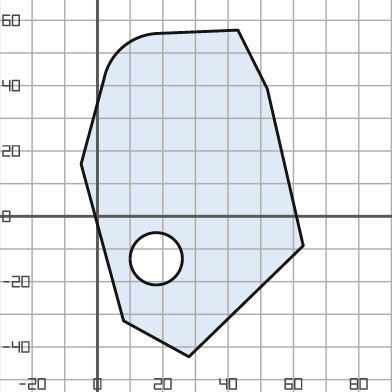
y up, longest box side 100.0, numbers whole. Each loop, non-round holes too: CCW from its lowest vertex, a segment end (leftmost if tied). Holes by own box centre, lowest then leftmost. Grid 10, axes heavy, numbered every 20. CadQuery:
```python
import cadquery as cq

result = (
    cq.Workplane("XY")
    .moveTo(28.0, -43.0)
    .lineTo(63.0, -9.0)
    .lineTo(52.0, 39.0)
    .lineTo(43.0, 57.0)
    .lineTo(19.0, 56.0)
    .threePointArc((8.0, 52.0), (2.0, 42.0))
    .lineTo(-5.0, 16.0)
    .lineTo(8.0, -32.0)
    .close()
    .moveTo(18.0, -13.0)
    .circle(8.0)
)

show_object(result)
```